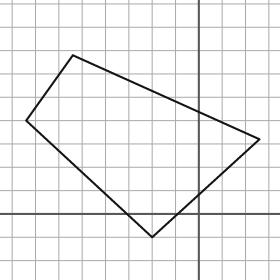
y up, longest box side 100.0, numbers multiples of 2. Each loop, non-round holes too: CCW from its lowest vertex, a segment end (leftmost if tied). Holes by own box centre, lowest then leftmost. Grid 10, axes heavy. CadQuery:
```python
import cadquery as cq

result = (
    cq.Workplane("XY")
    .moveTo(-20.0, -10.0)
    .lineTo(26.0, 32.0)
    .lineTo(-54.0, 68.0)
    .lineTo(-74.0, 40.0)
    .close()
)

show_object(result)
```